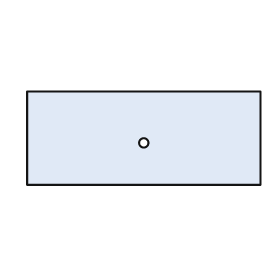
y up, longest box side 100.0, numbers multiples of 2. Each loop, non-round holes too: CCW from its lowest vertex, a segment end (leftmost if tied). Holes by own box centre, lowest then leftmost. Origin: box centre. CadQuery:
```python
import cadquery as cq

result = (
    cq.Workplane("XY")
    .moveTo(-50.0, -20.0)
    .lineTo(50.0, -20.0)
    .lineTo(50.0, 20.0)
    .lineTo(-50.0, 20.0)
    .close()
    .moveTo(0.0, -2.0)
    .circle(2.0)
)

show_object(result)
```